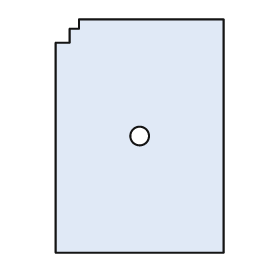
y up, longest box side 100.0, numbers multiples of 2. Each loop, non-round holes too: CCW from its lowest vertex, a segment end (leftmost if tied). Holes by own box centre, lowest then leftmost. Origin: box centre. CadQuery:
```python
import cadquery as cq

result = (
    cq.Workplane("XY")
    .moveTo(-36.0, -50.0)
    .lineTo(36.0, -50.0)
    .lineTo(36.0, 50.0)
    .lineTo(-26.0, 50.0)
    .lineTo(-26.0, 46.0)
    .lineTo(-30.0, 46.0)
    .lineTo(-30.0, 40.0)
    .lineTo(-36.0, 40.0)
    .close()
    .moveTo(0.0, 0.0)
    .circle(4.0)
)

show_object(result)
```